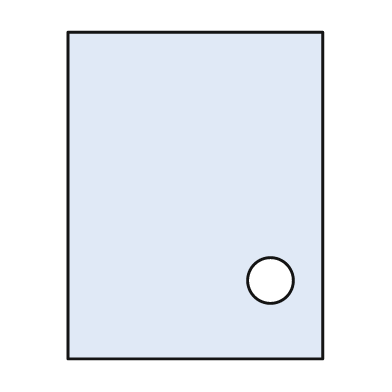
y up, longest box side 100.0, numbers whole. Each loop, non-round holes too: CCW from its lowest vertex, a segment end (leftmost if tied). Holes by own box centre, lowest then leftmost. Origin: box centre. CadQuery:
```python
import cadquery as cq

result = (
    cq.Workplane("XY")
    .moveTo(-39.0, -50.0)
    .lineTo(39.0, -50.0)
    .lineTo(39.0, 50.0)
    .lineTo(-39.0, 50.0)
    .close()
    .moveTo(23.0, -26.0)
    .circle(7.0)
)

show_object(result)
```